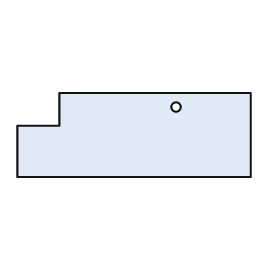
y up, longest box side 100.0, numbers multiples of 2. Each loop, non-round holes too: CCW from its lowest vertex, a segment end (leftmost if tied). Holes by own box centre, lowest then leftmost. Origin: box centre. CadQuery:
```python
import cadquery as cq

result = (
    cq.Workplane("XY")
    .moveTo(-50.0, -18.0)
    .lineTo(50.0, -18.0)
    .lineTo(50.0, 18.0)
    .lineTo(-32.0, 18.0)
    .lineTo(-32.0, 4.0)
    .lineTo(-50.0, 4.0)
    .close()
    .moveTo(18.0, 12.0)
    .circle(2.0)
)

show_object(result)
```